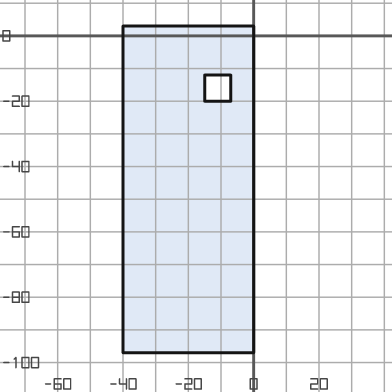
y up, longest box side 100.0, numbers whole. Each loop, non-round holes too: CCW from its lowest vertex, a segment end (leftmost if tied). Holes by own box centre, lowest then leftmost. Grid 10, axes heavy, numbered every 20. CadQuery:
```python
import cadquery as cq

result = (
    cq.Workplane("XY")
    .moveTo(-40.0, -97.0)
    .lineTo(0.0, -97.0)
    .lineTo(0.0, 3.0)
    .lineTo(-40.0, 3.0)
    .close()
    .moveTo(-15.0, -20.0)
    .lineTo(-7.0, -20.0)
    .lineTo(-7.0, -12.0)
    .lineTo(-15.0, -12.0)
    .close()
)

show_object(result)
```